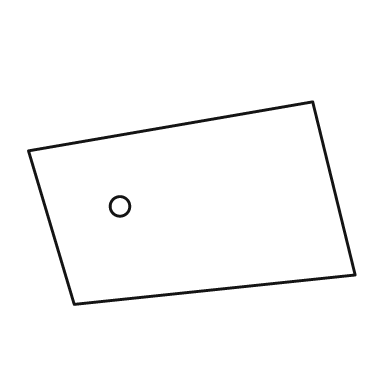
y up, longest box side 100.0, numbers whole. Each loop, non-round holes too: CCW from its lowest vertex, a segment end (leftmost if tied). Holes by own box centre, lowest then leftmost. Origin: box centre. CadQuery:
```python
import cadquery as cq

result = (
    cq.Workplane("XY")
    .moveTo(-36.0, -31.0)
    .lineTo(50.0, -22.0)
    .lineTo(37.0, 31.0)
    .lineTo(-50.0, 16.0)
    .close()
    .moveTo(-22.0, -1.0)
    .circle(3.0)
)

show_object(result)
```